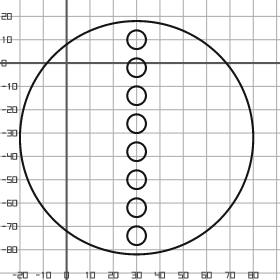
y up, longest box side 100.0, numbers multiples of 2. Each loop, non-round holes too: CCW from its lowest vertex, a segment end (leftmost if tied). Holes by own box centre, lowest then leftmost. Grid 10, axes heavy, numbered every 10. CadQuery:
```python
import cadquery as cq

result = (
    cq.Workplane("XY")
    .moveTo(30.0, -32.0)
    .circle(50.0)
    .moveTo(30.0, -74.0)
    .circle(4.0)
    .moveTo(30.0, -62.0)
    .circle(4.0)
    .moveTo(30.0, -50.0)
    .circle(4.0)
    .moveTo(30.0, -38.0)
    .circle(4.0)
    .moveTo(30.0, -26.0)
    .circle(4.0)
    .moveTo(30.0, -14.0)
    .circle(4.0)
    .moveTo(30.0, -2.0)
    .circle(4.0)
    .moveTo(30.0, 10.0)
    .circle(4.0)
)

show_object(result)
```